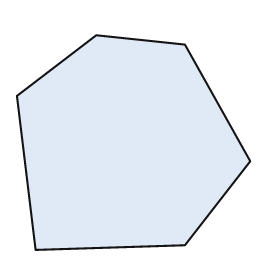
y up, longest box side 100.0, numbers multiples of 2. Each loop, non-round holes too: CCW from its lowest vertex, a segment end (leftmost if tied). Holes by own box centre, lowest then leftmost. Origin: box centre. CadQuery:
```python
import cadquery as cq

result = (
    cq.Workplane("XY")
    .moveTo(-42.0, -46.0)
    .lineTo(22.0, -44.0)
    .lineTo(50.0, -8.0)
    .lineTo(22.0, 42.0)
    .lineTo(-16.0, 46.0)
    .lineTo(-50.0, 20.0)
    .close()
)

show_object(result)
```